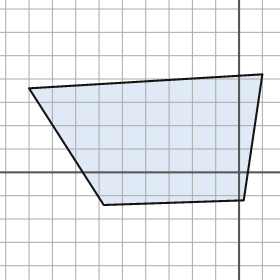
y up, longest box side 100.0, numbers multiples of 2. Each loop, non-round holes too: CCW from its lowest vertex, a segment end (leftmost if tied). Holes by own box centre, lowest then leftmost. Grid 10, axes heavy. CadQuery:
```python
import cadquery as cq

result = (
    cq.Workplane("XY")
    .moveTo(-58.0, -14.0)
    .lineTo(2.0, -12.0)
    .lineTo(10.0, 42.0)
    .lineTo(-90.0, 36.0)
    .close()
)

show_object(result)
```